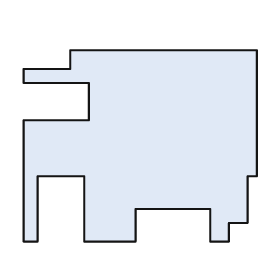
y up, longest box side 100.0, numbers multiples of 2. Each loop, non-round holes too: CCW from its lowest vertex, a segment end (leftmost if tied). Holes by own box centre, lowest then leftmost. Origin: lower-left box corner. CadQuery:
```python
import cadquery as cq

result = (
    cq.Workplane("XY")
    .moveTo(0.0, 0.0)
    .lineTo(6.0, 0.0)
    .lineTo(6.0, 28.0)
    .lineTo(26.0, 28.0)
    .lineTo(26.0, 0.0)
    .lineTo(48.0, 0.0)
    .lineTo(48.0, 14.0)
    .lineTo(80.0, 14.0)
    .lineTo(80.0, 0.0)
    .lineTo(88.0, 0.0)
    .lineTo(88.0, 8.0)
    .lineTo(96.0, 8.0)
    .lineTo(96.0, 28.0)
    .lineTo(100.0, 28.0)
    .lineTo(100.0, 82.0)
    .lineTo(20.0, 82.0)
    .lineTo(20.0, 74.0)
    .lineTo(0.0, 74.0)
    .lineTo(0.0, 68.0)
    .lineTo(28.0, 68.0)
    .lineTo(28.0, 52.0)
    .lineTo(0.0, 52.0)
    .close()
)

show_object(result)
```